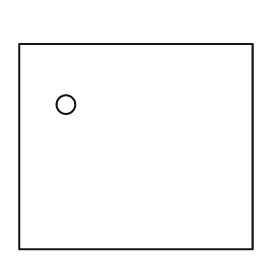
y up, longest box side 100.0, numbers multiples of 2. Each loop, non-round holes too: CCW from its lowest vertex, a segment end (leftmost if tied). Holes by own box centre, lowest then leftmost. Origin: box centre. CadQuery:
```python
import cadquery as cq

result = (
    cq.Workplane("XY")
    .moveTo(-50.0, -44.0)
    .lineTo(50.0, -44.0)
    .lineTo(50.0, 44.0)
    .lineTo(-50.0, 44.0)
    .close()
    .moveTo(-30.0, 18.0)
    .circle(4.0)
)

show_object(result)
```